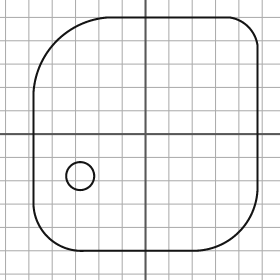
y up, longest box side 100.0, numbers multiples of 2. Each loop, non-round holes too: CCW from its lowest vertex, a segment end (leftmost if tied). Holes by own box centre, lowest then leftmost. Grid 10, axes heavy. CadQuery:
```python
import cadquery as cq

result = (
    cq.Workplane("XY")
    .moveTo(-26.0, -50.0)
    .lineTo(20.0, -50.0)
    .threePointArc((40.0, -42.0), (48.0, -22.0))
    .lineTo(48.0, 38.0)
    .threePointArc((44.0, 46.0), (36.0, 50.0))
    .lineTo(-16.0, 50.0)
    .threePointArc((-38.0, 40.0), (-48.0, 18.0))
    .lineTo(-48.0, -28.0)
    .threePointArc((-42.0, -44.0), (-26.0, -50.0))
    .close()
    .moveTo(-28.0, -18.0)
    .circle(6.0)
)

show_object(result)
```